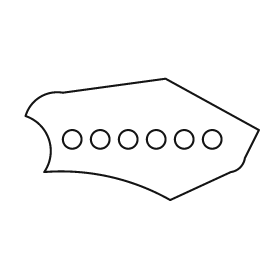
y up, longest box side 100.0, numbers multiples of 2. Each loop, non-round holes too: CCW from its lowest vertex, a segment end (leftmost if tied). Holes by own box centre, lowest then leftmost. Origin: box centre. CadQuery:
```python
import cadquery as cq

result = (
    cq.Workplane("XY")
    .moveTo(12.0, -26.0)
    .lineTo(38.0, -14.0)
    .threePointArc((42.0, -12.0), (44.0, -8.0))
    .lineTo(50.0, 4.0)
    .lineTo(10.0, 26.0)
    .lineTo(-34.0, 20.0)
    .threePointArc((-44.0, 18.0), (-50.0, 10.0))
    .threePointArc((-40.0, 0.0), (-42.0, -14.0))
    .threePointArc((-14.0, -16.0), (12.0, -26.0))
    .close()
    .moveTo(-30.0, 0.0)
    .circle(4.0)
    .moveTo(-18.0, 0.0)
    .circle(4.0)
    .moveTo(-6.0, 0.0)
    .circle(4.0)
    .moveTo(6.0, 0.0)
    .circle(4.0)
    .moveTo(18.0, 0.0)
    .circle(4.0)
    .moveTo(30.0, 0.0)
    .circle(4.0)
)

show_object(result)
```